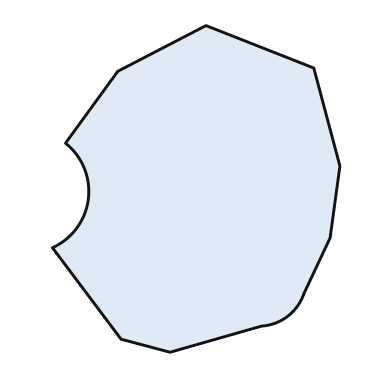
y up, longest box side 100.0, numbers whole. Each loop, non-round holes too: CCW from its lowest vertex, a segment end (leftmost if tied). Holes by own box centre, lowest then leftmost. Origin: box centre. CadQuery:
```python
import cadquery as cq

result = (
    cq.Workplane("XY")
    .moveTo(-8.0, -50.0)
    .lineTo(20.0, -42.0)
    .threePointArc((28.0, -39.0), (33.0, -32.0))
    .lineTo(41.0, -15.0)
    .lineTo(44.0, 7.0)
    .lineTo(36.0, 37.0)
    .lineTo(3.0, 50.0)
    .lineTo(-24.0, 36.0)
    .lineTo(-40.0, 14.0)
    .threePointArc((-33.0, -3.0), (-44.0, -18.0))
    .lineTo(-23.0, -46.0)
    .close()
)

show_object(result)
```